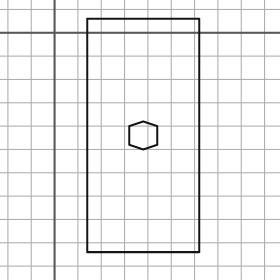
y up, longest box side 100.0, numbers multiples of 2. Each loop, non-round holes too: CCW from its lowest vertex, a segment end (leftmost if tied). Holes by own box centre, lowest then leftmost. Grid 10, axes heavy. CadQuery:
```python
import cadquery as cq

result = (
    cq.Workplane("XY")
    .moveTo(14.0, -94.0)
    .lineTo(62.0, -94.0)
    .lineTo(62.0, 6.0)
    .lineTo(14.0, 6.0)
    .close()
    .moveTo(38.0, -50.0)
    .lineTo(44.0, -48.0)
    .lineTo(44.0, -40.0)
    .lineTo(38.0, -38.0)
    .lineTo(32.0, -40.0)
    .lineTo(32.0, -48.0)
    .close()
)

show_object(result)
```